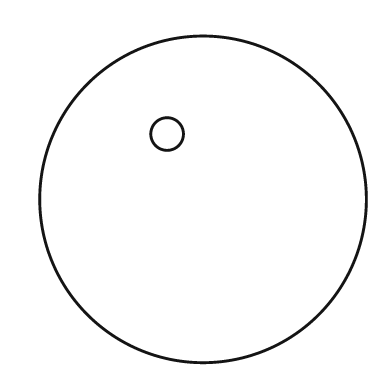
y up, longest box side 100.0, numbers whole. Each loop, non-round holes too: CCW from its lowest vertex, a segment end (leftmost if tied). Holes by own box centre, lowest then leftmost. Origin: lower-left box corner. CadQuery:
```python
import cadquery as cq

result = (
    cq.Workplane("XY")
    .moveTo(50.0, 50.0)
    .circle(50.0)
    .moveTo(39.0, 70.0)
    .circle(5.0)
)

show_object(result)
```